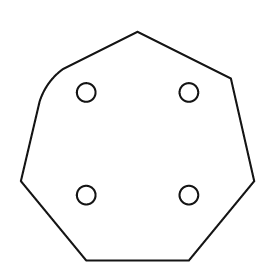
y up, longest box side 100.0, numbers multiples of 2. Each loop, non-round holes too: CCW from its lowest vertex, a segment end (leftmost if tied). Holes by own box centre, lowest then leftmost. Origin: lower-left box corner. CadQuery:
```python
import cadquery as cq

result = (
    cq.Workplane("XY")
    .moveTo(28.0, 0.0)
    .lineTo(72.0, 0.0)
    .lineTo(100.0, 34.0)
    .lineTo(90.0, 78.0)
    .lineTo(50.0, 98.0)
    .lineTo(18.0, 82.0)
    .threePointArc((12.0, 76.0), (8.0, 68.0))
    .lineTo(0.0, 34.0)
    .close()
    .moveTo(28.0, 28.0)
    .circle(4.0)
    .moveTo(72.0, 28.0)
    .circle(4.0)
    .moveTo(28.0, 72.0)
    .circle(4.0)
    .moveTo(72.0, 72.0)
    .circle(4.0)
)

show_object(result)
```